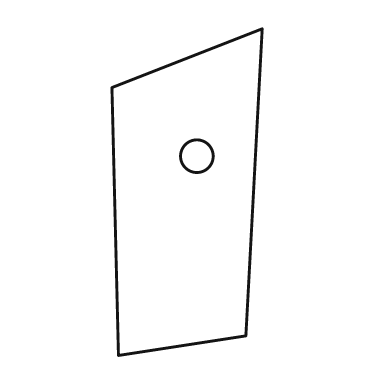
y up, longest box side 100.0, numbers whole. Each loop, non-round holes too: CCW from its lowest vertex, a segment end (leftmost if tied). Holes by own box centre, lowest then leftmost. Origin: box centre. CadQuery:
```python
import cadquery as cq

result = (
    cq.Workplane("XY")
    .moveTo(-21.0, -50.0)
    .lineTo(18.0, -44.0)
    .lineTo(23.0, 50.0)
    .lineTo(-23.0, 32.0)
    .close()
    .moveTo(3.0, 11.0)
    .circle(5.0)
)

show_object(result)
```